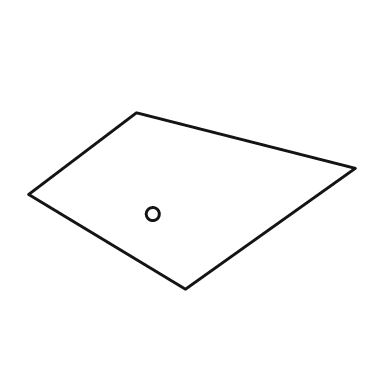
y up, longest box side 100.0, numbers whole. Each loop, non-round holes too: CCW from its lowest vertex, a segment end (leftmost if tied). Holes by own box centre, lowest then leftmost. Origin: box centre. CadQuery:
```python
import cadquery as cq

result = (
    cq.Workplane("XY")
    .moveTo(-2.0, -27.0)
    .lineTo(50.0, 10.0)
    .lineTo(-17.0, 27.0)
    .lineTo(-50.0, 2.0)
    .close()
    .moveTo(-12.0, -4.0)
    .circle(2.0)
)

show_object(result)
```